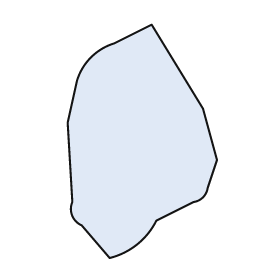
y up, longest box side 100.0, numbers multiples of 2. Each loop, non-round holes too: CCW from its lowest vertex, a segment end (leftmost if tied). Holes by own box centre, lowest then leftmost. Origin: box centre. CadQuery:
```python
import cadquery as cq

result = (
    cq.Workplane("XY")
    .moveTo(-14.0, -50.0)
    .threePointArc((-2.0, -44.0), (6.0, -34.0))
    .lineTo(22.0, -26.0)
    .threePointArc((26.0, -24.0), (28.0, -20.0))
    .lineTo(32.0, -8.0)
    .lineTo(26.0, 14.0)
    .lineTo(4.0, 50.0)
    .lineTo(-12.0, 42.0)
    .threePointArc((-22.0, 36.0), (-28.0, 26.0))
    .lineTo(-32.0, 8.0)
    .lineTo(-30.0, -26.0)
    .threePointArc((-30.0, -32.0), (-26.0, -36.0))
    .close()
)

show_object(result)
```